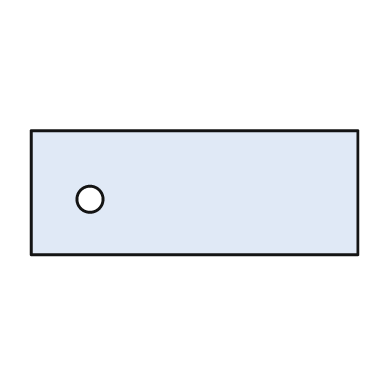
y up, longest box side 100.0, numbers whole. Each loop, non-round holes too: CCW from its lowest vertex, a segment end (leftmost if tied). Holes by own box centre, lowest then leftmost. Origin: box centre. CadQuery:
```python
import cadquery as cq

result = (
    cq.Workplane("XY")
    .moveTo(-50.0, -19.0)
    .lineTo(50.0, -19.0)
    .lineTo(50.0, 19.0)
    .lineTo(-50.0, 19.0)
    .close()
    .moveTo(-32.0, -2.0)
    .circle(4.0)
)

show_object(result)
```